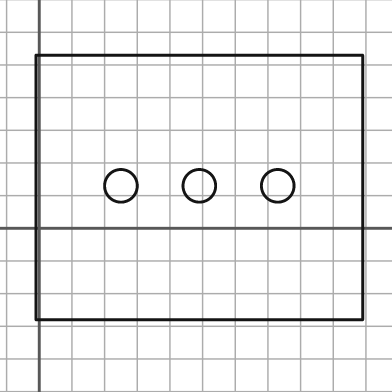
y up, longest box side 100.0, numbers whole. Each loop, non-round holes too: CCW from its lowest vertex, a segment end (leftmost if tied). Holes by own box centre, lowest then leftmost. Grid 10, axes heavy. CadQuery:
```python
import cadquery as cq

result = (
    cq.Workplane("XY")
    .moveTo(-1.0, -28.0)
    .lineTo(99.0, -28.0)
    .lineTo(99.0, 53.0)
    .lineTo(-1.0, 53.0)
    .close()
    .moveTo(25.0, 13.0)
    .circle(5.0)
    .moveTo(49.0, 13.0)
    .circle(5.0)
    .moveTo(73.0, 13.0)
    .circle(5.0)
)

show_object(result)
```